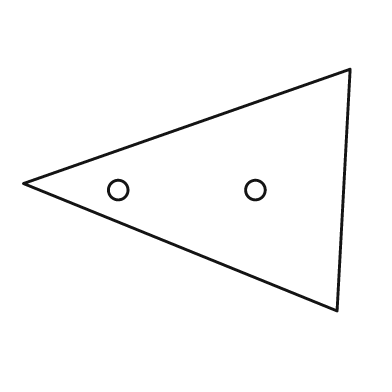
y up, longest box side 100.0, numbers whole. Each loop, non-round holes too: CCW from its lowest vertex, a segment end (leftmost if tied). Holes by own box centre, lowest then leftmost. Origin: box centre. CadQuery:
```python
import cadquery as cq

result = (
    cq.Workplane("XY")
    .moveTo(46.0, -37.0)
    .lineTo(50.0, 37.0)
    .lineTo(-50.0, 2.0)
    .close()
    .moveTo(-21.0, 0.0)
    .circle(3.0)
    .moveTo(21.0, 0.0)
    .circle(3.0)
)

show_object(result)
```